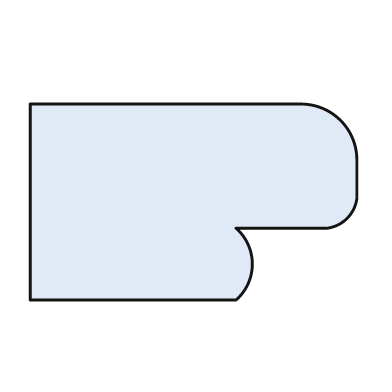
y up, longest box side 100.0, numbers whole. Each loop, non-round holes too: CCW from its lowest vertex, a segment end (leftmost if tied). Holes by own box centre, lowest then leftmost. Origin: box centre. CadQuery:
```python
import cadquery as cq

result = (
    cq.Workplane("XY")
    .moveTo(-50.0, -30.0)
    .lineTo(13.0, -30.0)
    .threePointArc((18.0, -19.0), (13.0, -8.0))
    .lineTo(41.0, -8.0)
    .threePointArc((47.0, -5.0), (50.0, 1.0))
    .lineTo(50.0, 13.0)
    .threePointArc((45.0, 25.0), (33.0, 30.0))
    .lineTo(-50.0, 30.0)
    .close()
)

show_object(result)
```